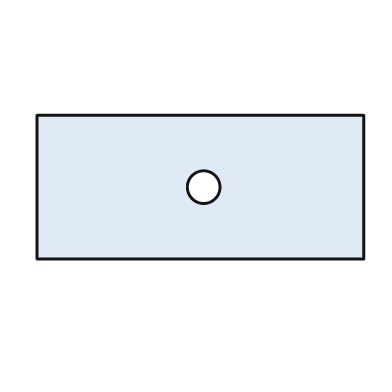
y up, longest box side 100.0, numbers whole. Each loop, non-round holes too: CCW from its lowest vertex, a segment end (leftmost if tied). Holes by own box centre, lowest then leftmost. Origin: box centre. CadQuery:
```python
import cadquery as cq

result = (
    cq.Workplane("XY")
    .moveTo(-50.0, -22.0)
    .lineTo(50.0, -22.0)
    .lineTo(50.0, 22.0)
    .lineTo(-50.0, 22.0)
    .close()
    .moveTo(1.0, 0.0)
    .circle(5.0)
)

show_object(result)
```